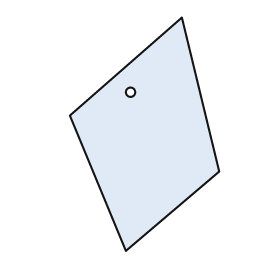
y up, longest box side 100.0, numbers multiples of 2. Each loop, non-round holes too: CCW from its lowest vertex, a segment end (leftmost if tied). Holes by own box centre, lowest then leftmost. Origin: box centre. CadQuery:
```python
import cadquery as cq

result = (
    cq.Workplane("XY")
    .moveTo(-8.0, -50.0)
    .lineTo(32.0, -16.0)
    .lineTo(16.0, 50.0)
    .lineTo(-32.0, 8.0)
    .close()
    .moveTo(-6.0, 18.0)
    .circle(2.0)
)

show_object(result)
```